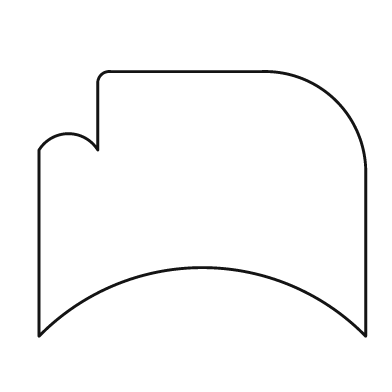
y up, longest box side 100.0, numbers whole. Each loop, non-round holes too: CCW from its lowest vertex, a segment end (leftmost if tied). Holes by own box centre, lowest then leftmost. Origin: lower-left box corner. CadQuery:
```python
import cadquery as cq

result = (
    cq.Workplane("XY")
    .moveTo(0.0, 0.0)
    .threePointArc((50.0, 21.0), (100.0, 0.0))
    .lineTo(100.0, 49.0)
    .threePointArc((91.0, 72.0), (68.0, 81.0))
    .lineTo(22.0, 81.0)
    .threePointArc((19.0, 80.0), (18.0, 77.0))
    .lineTo(18.0, 57.0)
    .threePointArc((9.0, 62.0), (0.0, 57.0))
    .close()
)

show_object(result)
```